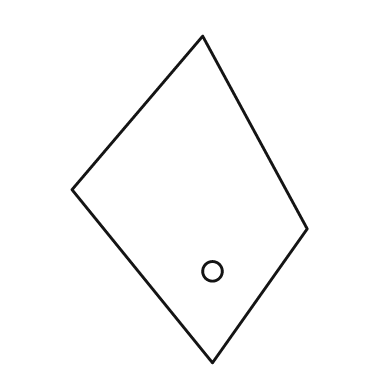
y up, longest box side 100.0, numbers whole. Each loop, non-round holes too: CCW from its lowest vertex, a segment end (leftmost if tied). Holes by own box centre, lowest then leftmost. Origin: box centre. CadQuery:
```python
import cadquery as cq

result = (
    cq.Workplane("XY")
    .moveTo(7.0, -50.0)
    .lineTo(36.0, -9.0)
    .lineTo(4.0, 50.0)
    .lineTo(-36.0, 3.0)
    .close()
    .moveTo(7.0, -22.0)
    .circle(3.0)
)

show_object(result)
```